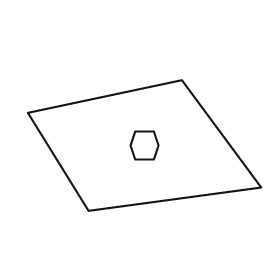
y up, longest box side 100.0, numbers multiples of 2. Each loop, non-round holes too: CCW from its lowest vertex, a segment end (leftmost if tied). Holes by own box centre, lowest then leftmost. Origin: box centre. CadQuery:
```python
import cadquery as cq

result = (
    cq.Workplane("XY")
    .moveTo(-24.0, -28.0)
    .lineTo(50.0, -18.0)
    .lineTo(16.0, 28.0)
    .lineTo(-50.0, 14.0)
    .close()
    .moveTo(-4.0, -6.0)
    .lineTo(4.0, -6.0)
    .lineTo(6.0, 0.0)
    .lineTo(4.0, 6.0)
    .lineTo(-4.0, 6.0)
    .lineTo(-6.0, 0.0)
    .close()
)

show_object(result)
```